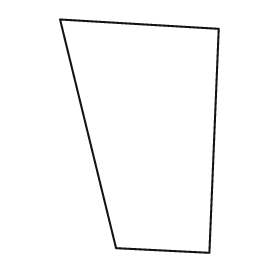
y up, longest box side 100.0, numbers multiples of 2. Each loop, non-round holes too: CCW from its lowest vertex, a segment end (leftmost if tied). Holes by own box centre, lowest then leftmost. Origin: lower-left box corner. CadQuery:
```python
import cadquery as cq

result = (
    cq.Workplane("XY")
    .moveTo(64.0, 0.0)
    .lineTo(68.0, 96.0)
    .lineTo(0.0, 100.0)
    .lineTo(24.0, 2.0)
    .close()
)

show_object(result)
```